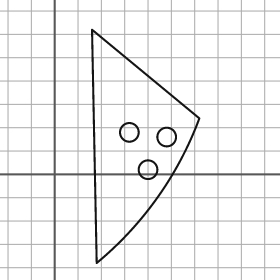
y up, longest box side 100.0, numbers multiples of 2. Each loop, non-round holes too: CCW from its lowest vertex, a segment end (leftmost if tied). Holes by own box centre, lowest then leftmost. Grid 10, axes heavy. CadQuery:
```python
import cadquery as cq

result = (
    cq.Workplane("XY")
    .moveTo(18.0, -38.0)
    .threePointArc((44.0, -10.0), (62.0, 24.0))
    .lineTo(16.0, 62.0)
    .close()
    .moveTo(40.0, 2.0)
    .circle(4.0)
    .moveTo(48.0, 16.0)
    .circle(4.0)
    .moveTo(32.0, 18.0)
    .circle(4.0)
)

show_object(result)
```